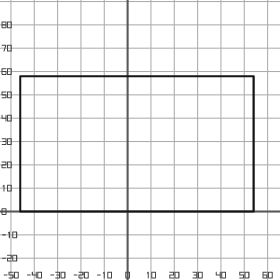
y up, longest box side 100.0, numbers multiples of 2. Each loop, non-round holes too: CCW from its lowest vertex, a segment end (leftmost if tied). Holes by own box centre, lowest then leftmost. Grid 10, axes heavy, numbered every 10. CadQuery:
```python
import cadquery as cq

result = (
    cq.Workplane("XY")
    .moveTo(-46.0, 0.0)
    .lineTo(54.0, 0.0)
    .lineTo(54.0, 58.0)
    .lineTo(-46.0, 58.0)
    .close()
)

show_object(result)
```